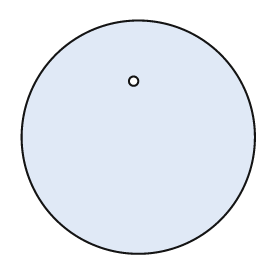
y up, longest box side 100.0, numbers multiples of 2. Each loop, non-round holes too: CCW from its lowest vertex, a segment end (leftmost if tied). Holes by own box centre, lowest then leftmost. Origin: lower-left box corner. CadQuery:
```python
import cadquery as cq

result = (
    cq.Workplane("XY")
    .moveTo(50.0, 50.0)
    .circle(50.0)
    .moveTo(48.0, 74.0)
    .circle(2.0)
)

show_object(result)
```